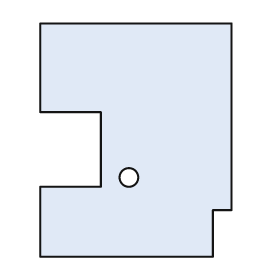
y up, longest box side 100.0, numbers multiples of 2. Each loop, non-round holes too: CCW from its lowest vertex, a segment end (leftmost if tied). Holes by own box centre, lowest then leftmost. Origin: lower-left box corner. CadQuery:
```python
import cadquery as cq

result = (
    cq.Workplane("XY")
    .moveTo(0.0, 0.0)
    .lineTo(74.0, 0.0)
    .lineTo(74.0, 20.0)
    .lineTo(82.0, 20.0)
    .lineTo(82.0, 100.0)
    .lineTo(0.0, 100.0)
    .lineTo(0.0, 62.0)
    .lineTo(26.0, 62.0)
    .lineTo(26.0, 30.0)
    .lineTo(0.0, 30.0)
    .close()
    .moveTo(38.0, 34.0)
    .circle(4.0)
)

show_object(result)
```